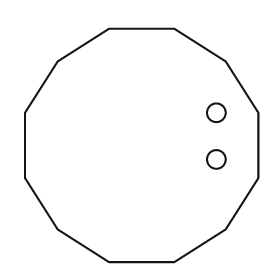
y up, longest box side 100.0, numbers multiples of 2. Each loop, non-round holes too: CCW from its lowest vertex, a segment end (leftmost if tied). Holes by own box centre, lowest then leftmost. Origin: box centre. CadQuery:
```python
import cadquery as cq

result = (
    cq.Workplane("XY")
    .moveTo(-14.0, -50.0)
    .lineTo(14.0, -50.0)
    .lineTo(36.0, -36.0)
    .lineTo(50.0, -14.0)
    .lineTo(50.0, 14.0)
    .lineTo(36.0, 36.0)
    .lineTo(14.0, 50.0)
    .lineTo(-14.0, 50.0)
    .lineTo(-36.0, 36.0)
    .lineTo(-50.0, 14.0)
    .lineTo(-50.0, -14.0)
    .lineTo(-36.0, -36.0)
    .close()
    .moveTo(32.0, -6.0)
    .circle(4.0)
    .moveTo(32.0, 14.0)
    .circle(4.0)
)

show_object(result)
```